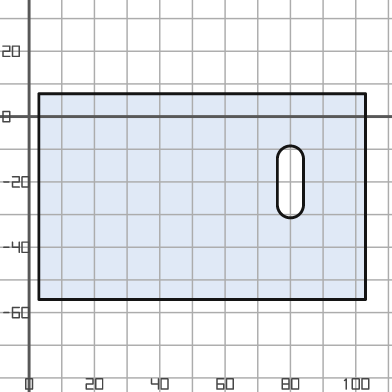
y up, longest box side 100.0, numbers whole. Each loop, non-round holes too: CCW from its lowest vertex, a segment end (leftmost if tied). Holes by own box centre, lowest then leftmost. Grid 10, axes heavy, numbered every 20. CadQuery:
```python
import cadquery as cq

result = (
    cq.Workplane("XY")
    .moveTo(3.0, -56.0)
    .lineTo(103.0, -56.0)
    .lineTo(103.0, 7.0)
    .lineTo(3.0, 7.0)
    .close()
    .moveTo(76.0, -27.0)
    .threePointArc((80.0, -31.0), (84.0, -27.0))
    .lineTo(84.0, -13.0)
    .threePointArc((80.0, -9.0), (76.0, -13.0))
    .close()
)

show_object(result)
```